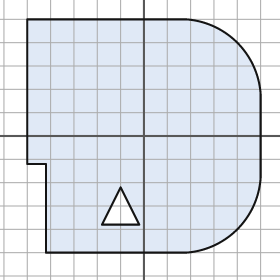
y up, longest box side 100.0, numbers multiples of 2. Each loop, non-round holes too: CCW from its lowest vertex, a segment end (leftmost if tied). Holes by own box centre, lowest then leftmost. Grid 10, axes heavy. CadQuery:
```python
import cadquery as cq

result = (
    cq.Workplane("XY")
    .moveTo(-42.0, -50.0)
    .lineTo(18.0, -50.0)
    .threePointArc((40.0, -40.0), (50.0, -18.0))
    .lineTo(50.0, 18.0)
    .threePointArc((40.0, 40.0), (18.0, 50.0))
    .lineTo(-50.0, 50.0)
    .lineTo(-50.0, -12.0)
    .lineTo(-42.0, -12.0)
    .close()
    .moveTo(-18.0, -38.0)
    .lineTo(-2.0, -38.0)
    .lineTo(-10.0, -22.0)
    .close()
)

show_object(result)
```